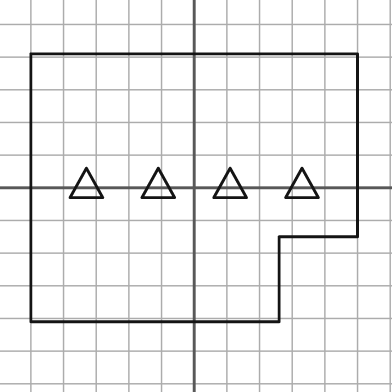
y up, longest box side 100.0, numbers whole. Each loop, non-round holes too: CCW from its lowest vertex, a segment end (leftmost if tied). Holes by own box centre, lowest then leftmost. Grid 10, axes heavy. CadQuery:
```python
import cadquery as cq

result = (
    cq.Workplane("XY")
    .moveTo(-50.0, -41.0)
    .lineTo(26.0, -41.0)
    .lineTo(26.0, -15.0)
    .lineTo(50.0, -15.0)
    .lineTo(50.0, 41.0)
    .lineTo(-50.0, 41.0)
    .close()
    .moveTo(-38.0, -3.0)
    .lineTo(-28.0, -3.0)
    .lineTo(-33.0, 6.0)
    .close()
    .moveTo(-16.0, -3.0)
    .lineTo(-6.0, -3.0)
    .lineTo(-11.0, 6.0)
    .close()
    .moveTo(6.0, -3.0)
    .lineTo(16.0, -3.0)
    .lineTo(11.0, 6.0)
    .close()
    .moveTo(28.0, -3.0)
    .lineTo(38.0, -3.0)
    .lineTo(33.0, 6.0)
    .close()
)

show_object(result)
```